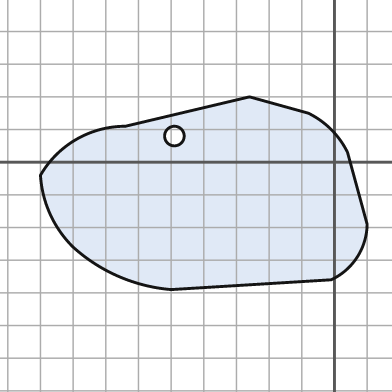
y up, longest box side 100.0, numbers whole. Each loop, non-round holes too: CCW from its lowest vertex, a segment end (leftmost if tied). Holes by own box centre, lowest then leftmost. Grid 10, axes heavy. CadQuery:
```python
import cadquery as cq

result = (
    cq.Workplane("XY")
    .moveTo(-50.0, -39.0)
    .lineTo(-1.0, -36.0)
    .threePointArc((7.0, -29.0), (10.0, -19.0))
    .lineTo(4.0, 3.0)
    .threePointArc((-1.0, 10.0), (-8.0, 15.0))
    .lineTo(-26.0, 20.0)
    .lineTo(-64.0, 11.0)
    .threePointArc((-79.0, 7.0), (-90.0, -4.0))
    .threePointArc((-87.0, -16.0), (-80.0, -26.0))
    .threePointArc((-66.0, -35.0), (-50.0, -39.0))
    .close()
    .moveTo(-49.0, 8.0)
    .circle(3.0)
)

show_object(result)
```